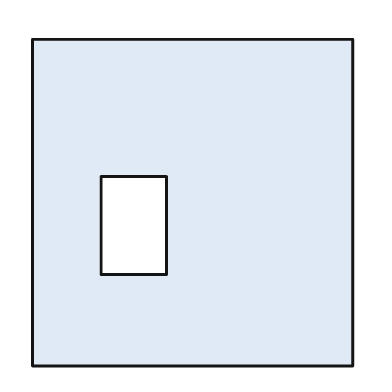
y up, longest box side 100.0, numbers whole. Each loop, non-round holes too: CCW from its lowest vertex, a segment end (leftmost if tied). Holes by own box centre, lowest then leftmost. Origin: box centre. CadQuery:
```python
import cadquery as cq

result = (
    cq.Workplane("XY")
    .moveTo(-49.0, -50.0)
    .lineTo(49.0, -50.0)
    .lineTo(49.0, 50.0)
    .lineTo(-49.0, 50.0)
    .close()
    .moveTo(-28.0, -22.0)
    .lineTo(-8.0, -22.0)
    .lineTo(-8.0, 8.0)
    .lineTo(-28.0, 8.0)
    .close()
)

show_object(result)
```